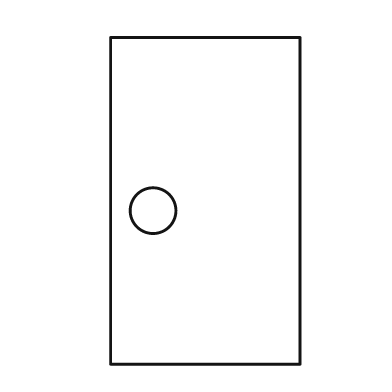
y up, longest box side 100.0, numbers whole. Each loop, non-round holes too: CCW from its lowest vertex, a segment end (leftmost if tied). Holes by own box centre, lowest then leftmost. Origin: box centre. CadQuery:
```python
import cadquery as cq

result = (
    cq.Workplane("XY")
    .moveTo(-29.0, -50.0)
    .lineTo(29.0, -50.0)
    .lineTo(29.0, 50.0)
    .lineTo(-29.0, 50.0)
    .close()
    .moveTo(-16.0, -3.0)
    .circle(7.0)
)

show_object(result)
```